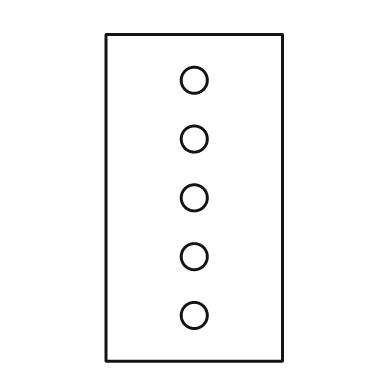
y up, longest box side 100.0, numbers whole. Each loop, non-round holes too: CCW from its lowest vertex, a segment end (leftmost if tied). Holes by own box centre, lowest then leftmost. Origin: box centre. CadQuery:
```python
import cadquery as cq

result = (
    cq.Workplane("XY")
    .moveTo(-27.0, -50.0)
    .lineTo(27.0, -50.0)
    .lineTo(27.0, 50.0)
    .lineTo(-27.0, 50.0)
    .close()
    .moveTo(0.0, -36.0)
    .circle(4.0)
    .moveTo(0.0, -18.0)
    .circle(4.0)
    .moveTo(0.0, 0.0)
    .circle(4.0)
    .moveTo(0.0, 18.0)
    .circle(4.0)
    .moveTo(0.0, 36.0)
    .circle(4.0)
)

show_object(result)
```